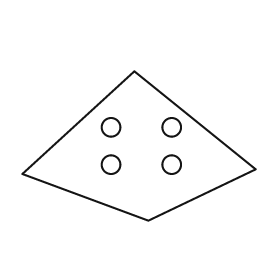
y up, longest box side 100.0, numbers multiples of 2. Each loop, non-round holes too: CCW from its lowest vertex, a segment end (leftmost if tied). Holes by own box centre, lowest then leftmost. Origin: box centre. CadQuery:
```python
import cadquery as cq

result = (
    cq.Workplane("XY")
    .moveTo(4.0, -32.0)
    .lineTo(50.0, -10.0)
    .lineTo(-2.0, 32.0)
    .lineTo(-50.0, -12.0)
    .close()
    .moveTo(-12.0, -8.0)
    .circle(4.0)
    .moveTo(14.0, -8.0)
    .circle(4.0)
    .moveTo(-12.0, 8.0)
    .circle(4.0)
    .moveTo(14.0, 8.0)
    .circle(4.0)
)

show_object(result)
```